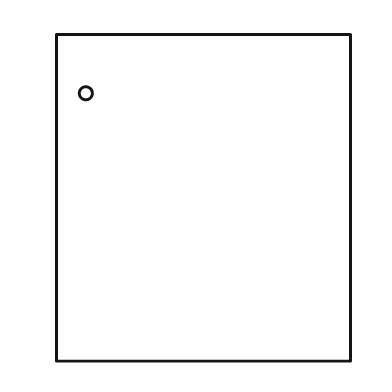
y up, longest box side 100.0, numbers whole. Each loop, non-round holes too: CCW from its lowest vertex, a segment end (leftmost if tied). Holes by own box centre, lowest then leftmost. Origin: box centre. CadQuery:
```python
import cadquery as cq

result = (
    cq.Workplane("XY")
    .moveTo(-45.0, -50.0)
    .lineTo(45.0, -50.0)
    .lineTo(45.0, 50.0)
    .lineTo(-45.0, 50.0)
    .close()
    .moveTo(-36.0, 32.0)
    .circle(2.0)
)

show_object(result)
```